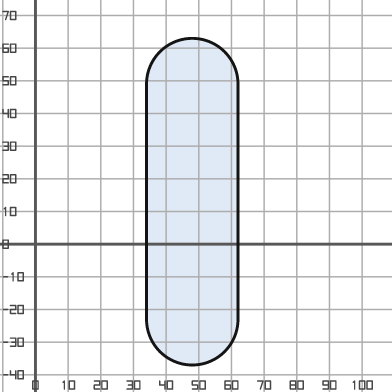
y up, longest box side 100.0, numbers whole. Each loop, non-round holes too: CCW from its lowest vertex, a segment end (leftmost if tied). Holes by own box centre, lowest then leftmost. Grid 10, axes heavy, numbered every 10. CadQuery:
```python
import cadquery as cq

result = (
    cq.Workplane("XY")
    .moveTo(34.0, -23.0)
    .threePointArc((48.0, -37.0), (62.0, -23.0))
    .lineTo(62.0, 49.0)
    .threePointArc((48.0, 63.0), (34.0, 49.0))
    .close()
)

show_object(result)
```